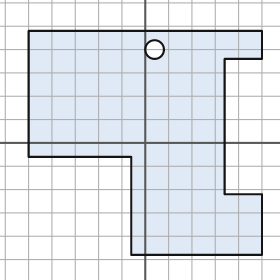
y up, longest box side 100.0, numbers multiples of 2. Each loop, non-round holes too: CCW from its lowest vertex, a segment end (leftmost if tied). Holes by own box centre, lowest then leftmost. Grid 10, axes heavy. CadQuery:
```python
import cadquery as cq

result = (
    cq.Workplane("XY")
    .moveTo(-6.0, -48.0)
    .lineTo(50.0, -48.0)
    .lineTo(50.0, -22.0)
    .lineTo(34.0, -22.0)
    .lineTo(34.0, 36.0)
    .lineTo(50.0, 36.0)
    .lineTo(50.0, 48.0)
    .lineTo(-50.0, 48.0)
    .lineTo(-50.0, -6.0)
    .lineTo(-6.0, -6.0)
    .close()
    .moveTo(4.0, 40.0)
    .circle(4.0)
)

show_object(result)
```